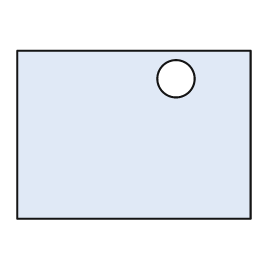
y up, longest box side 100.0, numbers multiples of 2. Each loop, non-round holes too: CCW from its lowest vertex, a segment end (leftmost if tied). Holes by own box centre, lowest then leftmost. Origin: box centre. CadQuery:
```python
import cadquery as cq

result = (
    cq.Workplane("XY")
    .moveTo(-50.0, -36.0)
    .lineTo(50.0, -36.0)
    .lineTo(50.0, 36.0)
    .lineTo(-50.0, 36.0)
    .close()
    .moveTo(18.0, 24.0)
    .circle(8.0)
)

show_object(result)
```